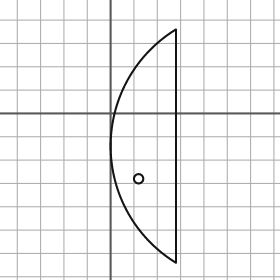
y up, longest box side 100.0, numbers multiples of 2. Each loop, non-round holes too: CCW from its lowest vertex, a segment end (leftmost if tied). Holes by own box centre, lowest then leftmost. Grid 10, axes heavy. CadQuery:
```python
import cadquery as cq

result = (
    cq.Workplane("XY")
    .moveTo(28.0, -64.0)
    .lineTo(28.0, 36.0)
    .threePointArc((0.0, -14.0), (28.0, -64.0))
    .close()
    .moveTo(12.0, -28.0)
    .circle(2.0)
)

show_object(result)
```